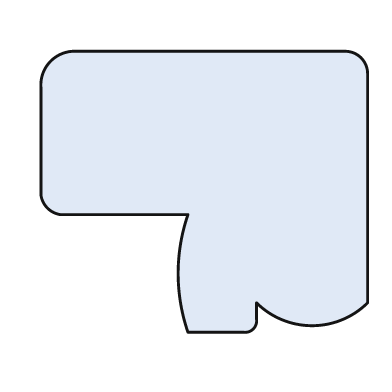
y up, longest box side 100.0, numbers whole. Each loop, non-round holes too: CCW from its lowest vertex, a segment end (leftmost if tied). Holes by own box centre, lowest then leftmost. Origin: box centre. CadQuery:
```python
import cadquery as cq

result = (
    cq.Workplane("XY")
    .moveTo(-5.0, -43.0)
    .lineTo(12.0, -43.0)
    .threePointArc((15.0, -42.0), (16.0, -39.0))
    .lineTo(16.0, -34.0)
    .threePointArc((33.0, -41.0), (50.0, -34.0))
    .lineTo(50.0, 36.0)
    .threePointArc((48.0, 41.0), (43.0, 43.0))
    .lineTo(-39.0, 43.0)
    .threePointArc((-47.0, 40.0), (-50.0, 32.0))
    .lineTo(-50.0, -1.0)
    .threePointArc((-48.0, -5.0), (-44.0, -7.0))
    .lineTo(-5.0, -7.0)
    .threePointArc((-8.0, -25.0), (-5.0, -43.0))
    .close()
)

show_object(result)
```